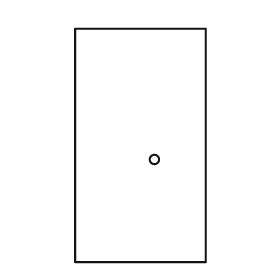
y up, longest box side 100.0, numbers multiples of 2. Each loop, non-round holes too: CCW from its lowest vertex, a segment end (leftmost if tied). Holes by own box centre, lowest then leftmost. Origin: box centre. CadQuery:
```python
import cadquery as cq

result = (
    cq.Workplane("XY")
    .moveTo(-28.0, -50.0)
    .lineTo(28.0, -50.0)
    .lineTo(28.0, 50.0)
    .lineTo(-28.0, 50.0)
    .close()
    .moveTo(6.0, -6.0)
    .circle(2.0)
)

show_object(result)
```